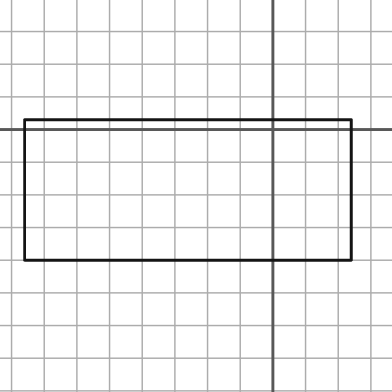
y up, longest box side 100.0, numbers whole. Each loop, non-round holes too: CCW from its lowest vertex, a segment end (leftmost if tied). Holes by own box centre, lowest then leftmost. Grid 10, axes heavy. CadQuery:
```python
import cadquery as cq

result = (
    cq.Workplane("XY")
    .moveTo(-76.0, -40.0)
    .lineTo(24.0, -40.0)
    .lineTo(24.0, 3.0)
    .lineTo(-76.0, 3.0)
    .close()
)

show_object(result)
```